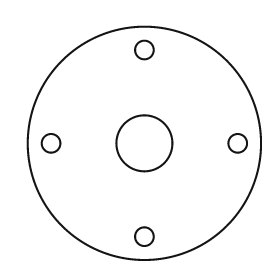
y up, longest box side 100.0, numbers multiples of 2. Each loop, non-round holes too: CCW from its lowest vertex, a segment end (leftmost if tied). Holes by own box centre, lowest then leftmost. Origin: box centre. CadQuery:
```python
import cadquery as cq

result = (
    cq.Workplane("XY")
    .moveTo(0.0, 0.0)
    .circle(50.0)
    .moveTo(0.0, -40.0)
    .circle(4.0)
    .moveTo(-40.0, 0.0)
    .circle(4.0)
    .moveTo(0.0, 0.0)
    .circle(12.0)
    .moveTo(40.0, 0.0)
    .circle(4.0)
    .moveTo(0.0, 40.0)
    .circle(4.0)
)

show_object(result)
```